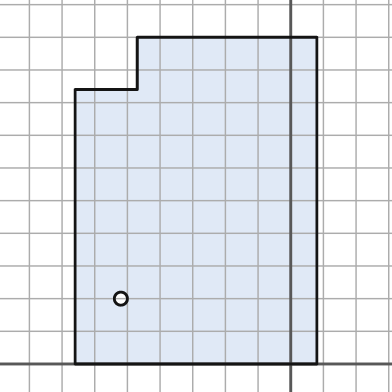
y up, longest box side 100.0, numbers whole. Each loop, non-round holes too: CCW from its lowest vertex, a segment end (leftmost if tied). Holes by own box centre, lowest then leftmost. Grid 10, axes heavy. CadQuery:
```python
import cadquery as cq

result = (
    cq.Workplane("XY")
    .moveTo(-66.0, 0.0)
    .lineTo(8.0, 0.0)
    .lineTo(8.0, 100.0)
    .lineTo(-47.0, 100.0)
    .lineTo(-47.0, 84.0)
    .lineTo(-66.0, 84.0)
    .close()
    .moveTo(-52.0, 20.0)
    .circle(2.0)
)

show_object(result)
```